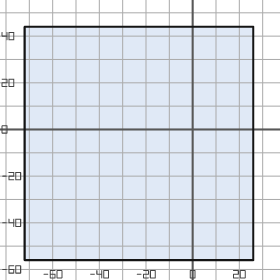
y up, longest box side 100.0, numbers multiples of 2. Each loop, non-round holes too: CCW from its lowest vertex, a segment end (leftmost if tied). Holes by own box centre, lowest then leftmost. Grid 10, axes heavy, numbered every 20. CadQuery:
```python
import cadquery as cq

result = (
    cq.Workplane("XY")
    .moveTo(-72.0, -56.0)
    .lineTo(26.0, -56.0)
    .lineTo(26.0, 44.0)
    .lineTo(-72.0, 44.0)
    .close()
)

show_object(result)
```